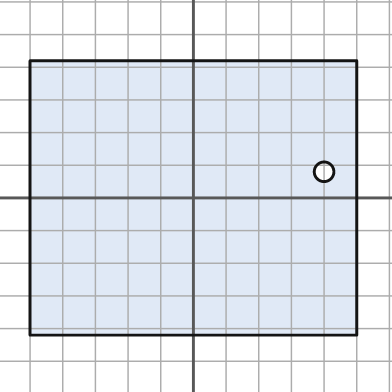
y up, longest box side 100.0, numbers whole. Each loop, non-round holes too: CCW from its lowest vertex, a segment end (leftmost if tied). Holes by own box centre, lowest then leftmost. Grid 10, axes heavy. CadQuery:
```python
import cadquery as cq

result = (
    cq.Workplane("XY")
    .moveTo(-50.0, -42.0)
    .lineTo(50.0, -42.0)
    .lineTo(50.0, 42.0)
    .lineTo(-50.0, 42.0)
    .close()
    .moveTo(40.0, 8.0)
    .circle(3.0)
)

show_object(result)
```